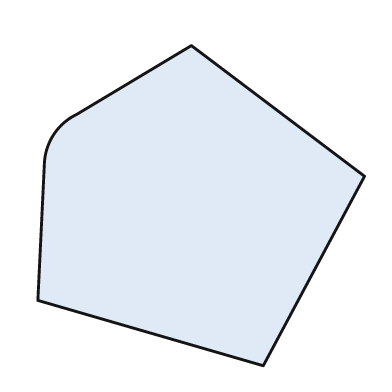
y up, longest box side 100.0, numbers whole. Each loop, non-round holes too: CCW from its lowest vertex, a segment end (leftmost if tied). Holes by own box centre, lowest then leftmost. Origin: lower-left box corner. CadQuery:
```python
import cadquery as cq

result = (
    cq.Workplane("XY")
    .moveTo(69.0, 0.0)
    .lineTo(100.0, 58.0)
    .lineTo(47.0, 98.0)
    .lineTo(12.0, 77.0)
    .threePointArc((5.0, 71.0), (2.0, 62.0))
    .lineTo(0.0, 20.0)
    .close()
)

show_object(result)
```